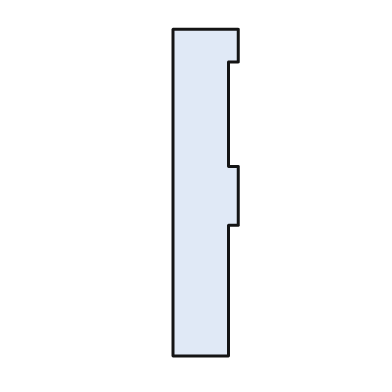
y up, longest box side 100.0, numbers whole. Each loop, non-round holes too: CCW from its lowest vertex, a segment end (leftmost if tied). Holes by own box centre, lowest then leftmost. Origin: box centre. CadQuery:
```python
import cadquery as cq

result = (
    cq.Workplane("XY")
    .moveTo(-10.0, -50.0)
    .lineTo(7.0, -50.0)
    .lineTo(7.0, -10.0)
    .lineTo(10.0, -10.0)
    .lineTo(10.0, 8.0)
    .lineTo(7.0, 8.0)
    .lineTo(7.0, 40.0)
    .lineTo(10.0, 40.0)
    .lineTo(10.0, 50.0)
    .lineTo(-10.0, 50.0)
    .close()
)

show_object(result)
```